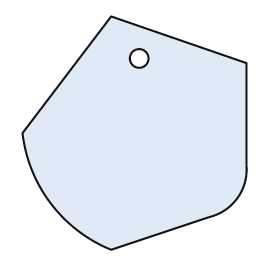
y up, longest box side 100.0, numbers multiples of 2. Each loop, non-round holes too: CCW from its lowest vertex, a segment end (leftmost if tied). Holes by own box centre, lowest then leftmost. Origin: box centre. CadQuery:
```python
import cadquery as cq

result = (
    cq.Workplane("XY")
    .moveTo(-10.0, -50.0)
    .lineTo(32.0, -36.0)
    .threePointArc((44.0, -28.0), (48.0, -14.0))
    .lineTo(48.0, 30.0)
    .lineTo(-10.0, 50.0)
    .lineTo(-48.0, 0.0)
    .threePointArc((-36.0, -30.0), (-10.0, -50.0))
    .close()
    .moveTo(2.0, 32.0)
    .circle(4.0)
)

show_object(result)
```